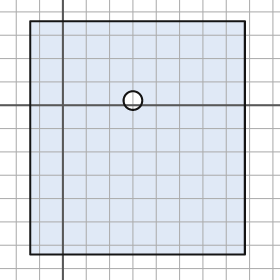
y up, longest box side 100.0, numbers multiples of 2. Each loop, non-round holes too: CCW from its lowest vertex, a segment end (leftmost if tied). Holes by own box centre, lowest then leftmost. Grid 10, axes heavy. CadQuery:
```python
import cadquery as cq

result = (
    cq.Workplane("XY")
    .moveTo(-14.0, -64.0)
    .lineTo(78.0, -64.0)
    .lineTo(78.0, 36.0)
    .lineTo(-14.0, 36.0)
    .close()
    .moveTo(30.0, 2.0)
    .circle(4.0)
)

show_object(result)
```